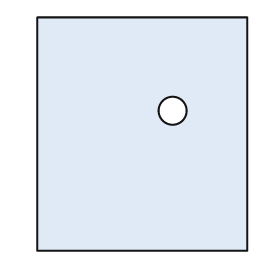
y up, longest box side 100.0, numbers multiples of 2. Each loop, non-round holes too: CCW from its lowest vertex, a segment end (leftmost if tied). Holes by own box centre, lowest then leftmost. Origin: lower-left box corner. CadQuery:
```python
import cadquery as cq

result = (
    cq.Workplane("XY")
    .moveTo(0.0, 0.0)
    .lineTo(90.0, 0.0)
    .lineTo(90.0, 100.0)
    .lineTo(0.0, 100.0)
    .close()
    .moveTo(58.0, 60.0)
    .circle(6.0)
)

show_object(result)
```